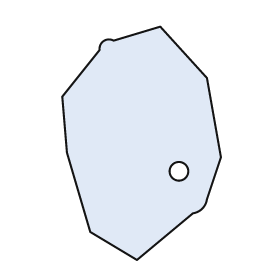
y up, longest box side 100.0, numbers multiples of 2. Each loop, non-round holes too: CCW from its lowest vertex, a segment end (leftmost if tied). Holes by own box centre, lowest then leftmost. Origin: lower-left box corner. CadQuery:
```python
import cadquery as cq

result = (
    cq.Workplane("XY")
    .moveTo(32.0, 0.0)
    .lineTo(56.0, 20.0)
    .threePointArc((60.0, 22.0), (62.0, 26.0))
    .lineTo(68.0, 44.0)
    .lineTo(62.0, 78.0)
    .lineTo(42.0, 100.0)
    .lineTo(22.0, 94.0)
    .threePointArc((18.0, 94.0), (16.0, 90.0))
    .lineTo(0.0, 70.0)
    .lineTo(2.0, 46.0)
    .lineTo(12.0, 12.0)
    .close()
    .moveTo(50.0, 38.0)
    .circle(4.0)
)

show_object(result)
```